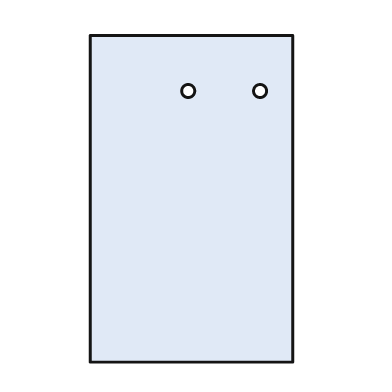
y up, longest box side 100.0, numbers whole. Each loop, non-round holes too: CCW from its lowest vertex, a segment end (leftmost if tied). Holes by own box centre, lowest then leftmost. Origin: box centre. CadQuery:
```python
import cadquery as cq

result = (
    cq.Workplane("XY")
    .moveTo(-31.0, -50.0)
    .lineTo(31.0, -50.0)
    .lineTo(31.0, 50.0)
    .lineTo(-31.0, 50.0)
    .close()
    .moveTo(-1.0, 33.0)
    .circle(2.0)
    .moveTo(21.0, 33.0)
    .circle(2.0)
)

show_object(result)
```